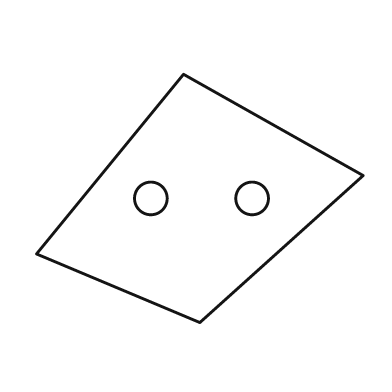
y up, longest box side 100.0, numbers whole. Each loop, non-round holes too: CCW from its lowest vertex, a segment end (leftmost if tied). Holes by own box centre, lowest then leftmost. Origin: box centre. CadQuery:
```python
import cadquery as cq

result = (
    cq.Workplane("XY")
    .moveTo(0.0, -38.0)
    .lineTo(50.0, 7.0)
    .lineTo(-5.0, 38.0)
    .lineTo(-50.0, -17.0)
    .close()
    .moveTo(-15.0, 0.0)
    .circle(5.0)
    .moveTo(16.0, 0.0)
    .circle(5.0)
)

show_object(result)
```